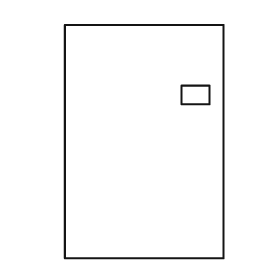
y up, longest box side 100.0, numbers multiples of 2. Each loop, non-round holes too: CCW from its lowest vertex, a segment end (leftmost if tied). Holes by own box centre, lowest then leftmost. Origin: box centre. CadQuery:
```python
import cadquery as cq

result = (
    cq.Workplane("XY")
    .moveTo(-34.0, -50.0)
    .lineTo(34.0, -50.0)
    .lineTo(34.0, 50.0)
    .lineTo(-34.0, 50.0)
    .close()
    .moveTo(16.0, 16.0)
    .lineTo(28.0, 16.0)
    .lineTo(28.0, 24.0)
    .lineTo(16.0, 24.0)
    .close()
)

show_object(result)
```